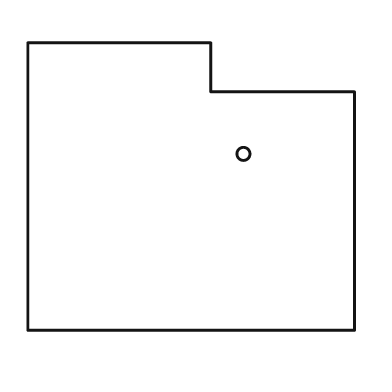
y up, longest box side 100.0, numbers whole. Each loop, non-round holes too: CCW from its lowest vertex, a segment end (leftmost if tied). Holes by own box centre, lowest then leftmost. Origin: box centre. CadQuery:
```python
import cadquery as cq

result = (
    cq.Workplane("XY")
    .moveTo(-50.0, -44.0)
    .lineTo(50.0, -44.0)
    .lineTo(50.0, 29.0)
    .lineTo(6.0, 29.0)
    .lineTo(6.0, 44.0)
    .lineTo(-50.0, 44.0)
    .close()
    .moveTo(16.0, 10.0)
    .circle(2.0)
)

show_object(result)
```